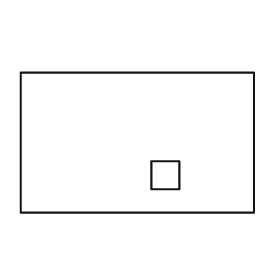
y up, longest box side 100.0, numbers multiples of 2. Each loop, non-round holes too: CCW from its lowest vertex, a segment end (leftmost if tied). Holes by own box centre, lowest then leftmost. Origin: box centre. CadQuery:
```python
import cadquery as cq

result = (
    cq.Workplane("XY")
    .moveTo(-50.0, -30.0)
    .lineTo(50.0, -30.0)
    .lineTo(50.0, 30.0)
    .lineTo(-50.0, 30.0)
    .close()
    .moveTo(6.0, -20.0)
    .lineTo(18.0, -20.0)
    .lineTo(18.0, -8.0)
    .lineTo(6.0, -8.0)
    .close()
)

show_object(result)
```